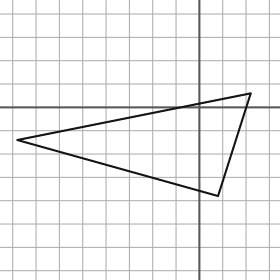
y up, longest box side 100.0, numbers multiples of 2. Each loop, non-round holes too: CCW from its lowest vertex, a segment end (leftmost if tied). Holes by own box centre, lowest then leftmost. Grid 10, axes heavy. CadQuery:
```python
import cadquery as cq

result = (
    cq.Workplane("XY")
    .moveTo(8.0, -38.0)
    .lineTo(22.0, 6.0)
    .lineTo(-78.0, -14.0)
    .close()
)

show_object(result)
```